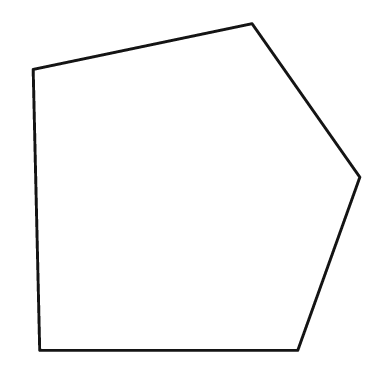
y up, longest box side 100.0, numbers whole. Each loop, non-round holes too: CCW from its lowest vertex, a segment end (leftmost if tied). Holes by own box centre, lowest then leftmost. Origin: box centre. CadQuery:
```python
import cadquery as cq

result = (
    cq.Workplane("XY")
    .moveTo(-48.0, -50.0)
    .lineTo(31.0, -50.0)
    .lineTo(50.0, 3.0)
    .lineTo(17.0, 50.0)
    .lineTo(-50.0, 36.0)
    .close()
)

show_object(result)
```